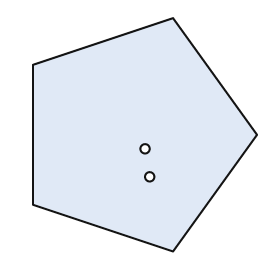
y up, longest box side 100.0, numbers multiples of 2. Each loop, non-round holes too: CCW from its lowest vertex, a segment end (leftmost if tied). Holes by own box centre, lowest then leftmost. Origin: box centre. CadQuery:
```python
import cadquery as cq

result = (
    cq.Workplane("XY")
    .moveTo(12.0, -50.0)
    .lineTo(48.0, 0.0)
    .lineTo(12.0, 50.0)
    .lineTo(-48.0, 30.0)
    .lineTo(-48.0, -30.0)
    .close()
    .moveTo(2.0, -18.0)
    .circle(2.0)
    .moveTo(0.0, -6.0)
    .circle(2.0)
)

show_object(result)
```